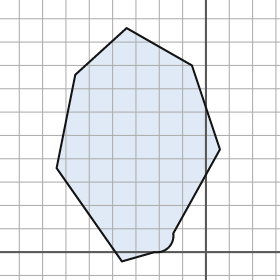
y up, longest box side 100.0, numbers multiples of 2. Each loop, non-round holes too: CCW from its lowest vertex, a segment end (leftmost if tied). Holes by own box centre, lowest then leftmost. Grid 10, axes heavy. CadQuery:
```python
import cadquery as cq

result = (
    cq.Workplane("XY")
    .moveTo(-36.0, -4.0)
    .lineTo(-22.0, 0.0)
    .threePointArc((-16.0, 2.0), (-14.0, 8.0))
    .lineTo(6.0, 44.0)
    .lineTo(-6.0, 80.0)
    .lineTo(-34.0, 96.0)
    .lineTo(-56.0, 76.0)
    .lineTo(-64.0, 36.0)
    .close()
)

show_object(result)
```